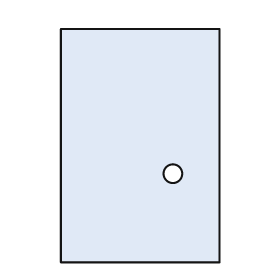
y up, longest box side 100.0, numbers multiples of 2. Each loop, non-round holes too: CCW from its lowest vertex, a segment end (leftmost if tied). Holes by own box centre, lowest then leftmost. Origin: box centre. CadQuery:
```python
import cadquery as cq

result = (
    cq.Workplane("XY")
    .moveTo(-34.0, -50.0)
    .lineTo(34.0, -50.0)
    .lineTo(34.0, 50.0)
    .lineTo(-34.0, 50.0)
    .close()
    .moveTo(14.0, -12.0)
    .circle(4.0)
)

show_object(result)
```